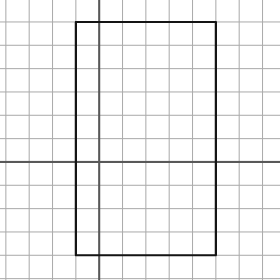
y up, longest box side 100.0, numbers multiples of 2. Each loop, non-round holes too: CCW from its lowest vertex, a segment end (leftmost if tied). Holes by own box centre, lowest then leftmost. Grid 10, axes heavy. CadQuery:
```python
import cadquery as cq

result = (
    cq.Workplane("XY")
    .moveTo(-10.0, -40.0)
    .lineTo(50.0, -40.0)
    .lineTo(50.0, 60.0)
    .lineTo(-10.0, 60.0)
    .close()
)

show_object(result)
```